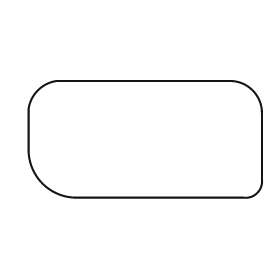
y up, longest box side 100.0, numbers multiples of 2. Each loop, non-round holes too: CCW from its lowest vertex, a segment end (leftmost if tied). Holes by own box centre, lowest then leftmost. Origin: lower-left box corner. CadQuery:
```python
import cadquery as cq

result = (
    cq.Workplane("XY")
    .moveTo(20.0, 0.0)
    .lineTo(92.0, 0.0)
    .threePointArc((98.0, 2.0), (100.0, 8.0))
    .lineTo(100.0, 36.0)
    .threePointArc((96.0, 46.0), (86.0, 50.0))
    .lineTo(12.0, 50.0)
    .threePointArc((4.0, 46.0), (0.0, 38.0))
    .lineTo(0.0, 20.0)
    .threePointArc((6.0, 6.0), (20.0, 0.0))
    .close()
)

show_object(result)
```